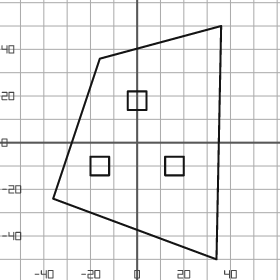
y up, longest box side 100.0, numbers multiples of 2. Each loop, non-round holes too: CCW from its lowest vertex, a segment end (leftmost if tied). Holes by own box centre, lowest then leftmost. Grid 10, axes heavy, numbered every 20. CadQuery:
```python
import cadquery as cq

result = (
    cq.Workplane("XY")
    .moveTo(34.0, -50.0)
    .lineTo(36.0, 50.0)
    .lineTo(-16.0, 36.0)
    .lineTo(-36.0, -24.0)
    .close()
    .moveTo(-20.0, -14.0)
    .lineTo(-12.0, -14.0)
    .lineTo(-12.0, -6.0)
    .lineTo(-20.0, -6.0)
    .close()
    .moveTo(12.0, -14.0)
    .lineTo(20.0, -14.0)
    .lineTo(20.0, -6.0)
    .lineTo(12.0, -6.0)
    .close()
    .moveTo(-4.0, 14.0)
    .lineTo(4.0, 14.0)
    .lineTo(4.0, 22.0)
    .lineTo(-4.0, 22.0)
    .close()
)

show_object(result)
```